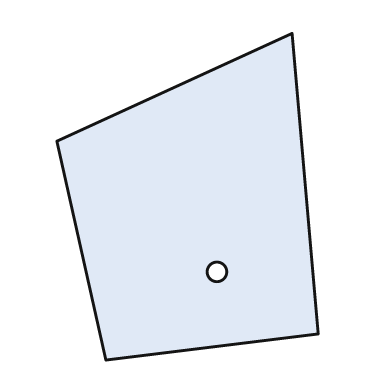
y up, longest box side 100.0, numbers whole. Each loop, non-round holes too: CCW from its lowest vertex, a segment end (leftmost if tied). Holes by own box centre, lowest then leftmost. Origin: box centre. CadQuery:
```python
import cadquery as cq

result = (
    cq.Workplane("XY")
    .moveTo(-25.0, -50.0)
    .lineTo(40.0, -42.0)
    .lineTo(32.0, 50.0)
    .lineTo(-40.0, 17.0)
    .close()
    .moveTo(9.0, -23.0)
    .circle(3.0)
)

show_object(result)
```